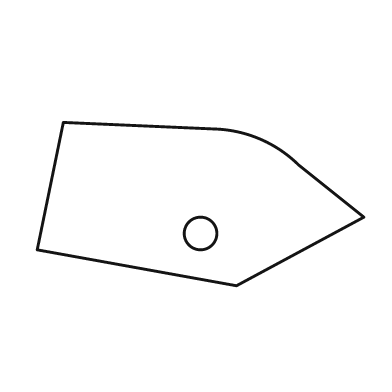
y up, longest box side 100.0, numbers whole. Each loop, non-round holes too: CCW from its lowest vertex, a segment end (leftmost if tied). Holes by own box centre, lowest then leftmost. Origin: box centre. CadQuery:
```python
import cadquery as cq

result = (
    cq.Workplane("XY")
    .moveTo(11.0, -25.0)
    .lineTo(50.0, -4.0)
    .lineTo(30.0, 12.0)
    .threePointArc((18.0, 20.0), (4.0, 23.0))
    .lineTo(-42.0, 25.0)
    .lineTo(-50.0, -14.0)
    .close()
    .moveTo(0.0, -9.0)
    .circle(5.0)
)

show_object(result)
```